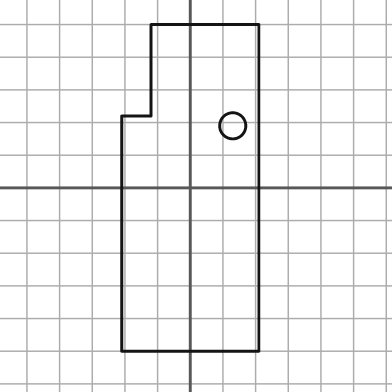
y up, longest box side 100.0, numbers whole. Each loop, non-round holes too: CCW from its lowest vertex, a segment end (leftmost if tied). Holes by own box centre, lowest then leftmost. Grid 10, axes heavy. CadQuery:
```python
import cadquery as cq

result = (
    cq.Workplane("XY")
    .moveTo(-21.0, -50.0)
    .lineTo(21.0, -50.0)
    .lineTo(21.0, 50.0)
    .lineTo(-12.0, 50.0)
    .lineTo(-12.0, 22.0)
    .lineTo(-21.0, 22.0)
    .close()
    .moveTo(13.0, 19.0)
    .circle(4.0)
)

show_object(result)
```